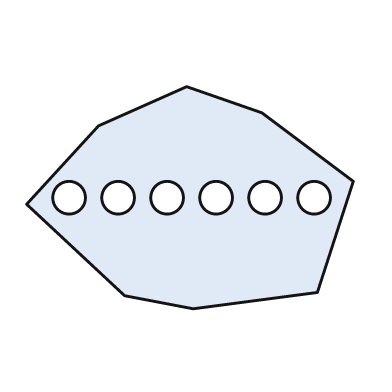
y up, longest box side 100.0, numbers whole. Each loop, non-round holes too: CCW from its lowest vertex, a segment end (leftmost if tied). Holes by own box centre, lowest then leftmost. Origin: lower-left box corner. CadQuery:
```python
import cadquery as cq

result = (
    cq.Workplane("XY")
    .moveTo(51.0, 0.0)
    .lineTo(89.0, 5.0)
    .lineTo(100.0, 39.0)
    .lineTo(72.0, 60.0)
    .lineTo(49.0, 68.0)
    .lineTo(22.0, 56.0)
    .lineTo(0.0, 32.0)
    .lineTo(30.0, 4.0)
    .close()
    .moveTo(13.0, 34.0)
    .circle(5.0)
    .moveTo(28.0, 34.0)
    .circle(5.0)
    .moveTo(43.0, 34.0)
    .circle(5.0)
    .moveTo(58.0, 34.0)
    .circle(5.0)
    .moveTo(73.0, 34.0)
    .circle(5.0)
    .moveTo(88.0, 34.0)
    .circle(5.0)
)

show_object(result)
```